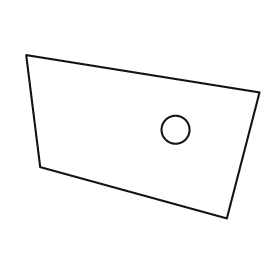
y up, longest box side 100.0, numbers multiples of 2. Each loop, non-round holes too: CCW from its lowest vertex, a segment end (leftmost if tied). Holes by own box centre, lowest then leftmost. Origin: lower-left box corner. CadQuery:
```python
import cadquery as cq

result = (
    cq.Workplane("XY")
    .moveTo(86.0, 0.0)
    .lineTo(100.0, 54.0)
    .lineTo(0.0, 70.0)
    .lineTo(6.0, 22.0)
    .close()
    .moveTo(64.0, 38.0)
    .circle(6.0)
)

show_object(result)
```